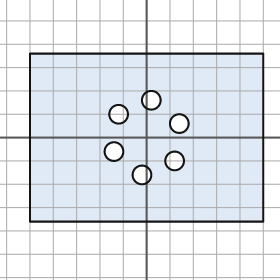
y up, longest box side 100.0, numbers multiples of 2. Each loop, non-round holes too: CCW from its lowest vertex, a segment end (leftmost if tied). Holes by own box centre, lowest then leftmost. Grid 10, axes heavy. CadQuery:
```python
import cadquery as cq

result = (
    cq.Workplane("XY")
    .moveTo(-50.0, -36.0)
    .lineTo(50.0, -36.0)
    .lineTo(50.0, 36.0)
    .lineTo(-50.0, 36.0)
    .close()
    .moveTo(-2.0, -16.0)
    .circle(4.0)
    .moveTo(12.0, -10.0)
    .circle(4.0)
    .moveTo(-14.0, -6.0)
    .circle(4.0)
    .moveTo(14.0, 6.0)
    .circle(4.0)
    .moveTo(-12.0, 10.0)
    .circle(4.0)
    .moveTo(2.0, 16.0)
    .circle(4.0)
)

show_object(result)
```